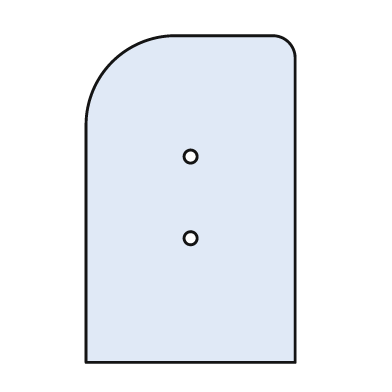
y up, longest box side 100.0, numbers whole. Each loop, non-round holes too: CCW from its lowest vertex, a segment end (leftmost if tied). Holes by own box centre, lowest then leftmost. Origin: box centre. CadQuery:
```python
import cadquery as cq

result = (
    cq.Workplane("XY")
    .moveTo(-32.0, -50.0)
    .lineTo(32.0, -50.0)
    .lineTo(32.0, 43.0)
    .threePointArc((30.0, 48.0), (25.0, 50.0))
    .lineTo(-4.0, 50.0)
    .threePointArc((-24.0, 42.0), (-32.0, 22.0))
    .close()
    .moveTo(0.0, -12.0)
    .circle(2.0)
    .moveTo(0.0, 13.0)
    .circle(2.0)
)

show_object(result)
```